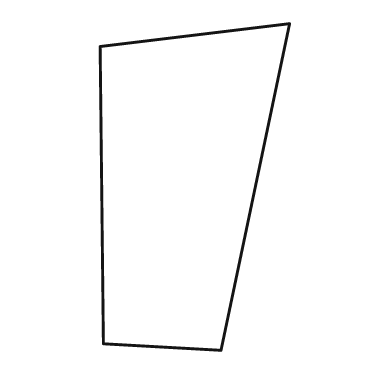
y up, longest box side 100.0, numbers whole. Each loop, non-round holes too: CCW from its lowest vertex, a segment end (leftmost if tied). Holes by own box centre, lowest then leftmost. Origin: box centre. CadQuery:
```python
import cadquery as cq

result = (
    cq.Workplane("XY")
    .moveTo(8.0, -50.0)
    .lineTo(29.0, 50.0)
    .lineTo(-29.0, 43.0)
    .lineTo(-28.0, -48.0)
    .close()
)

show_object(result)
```